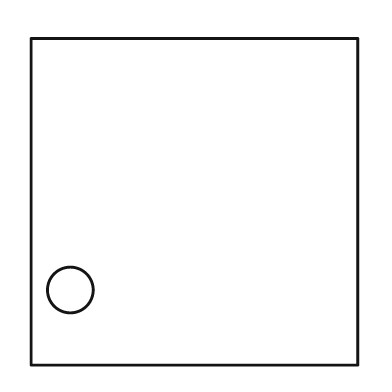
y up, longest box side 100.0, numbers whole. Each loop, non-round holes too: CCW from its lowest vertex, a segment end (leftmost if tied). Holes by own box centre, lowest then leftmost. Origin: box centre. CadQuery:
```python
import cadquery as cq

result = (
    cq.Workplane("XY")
    .moveTo(-50.0, -50.0)
    .lineTo(50.0, -50.0)
    .lineTo(50.0, 50.0)
    .lineTo(-50.0, 50.0)
    .close()
    .moveTo(-38.0, -27.0)
    .circle(7.0)
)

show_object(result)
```